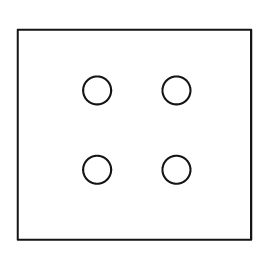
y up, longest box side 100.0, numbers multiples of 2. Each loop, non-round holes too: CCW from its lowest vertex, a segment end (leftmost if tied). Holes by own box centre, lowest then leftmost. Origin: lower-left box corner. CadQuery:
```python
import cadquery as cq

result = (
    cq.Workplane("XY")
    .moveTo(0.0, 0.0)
    .lineTo(100.0, 0.0)
    .lineTo(100.0, 90.0)
    .lineTo(0.0, 90.0)
    .close()
    .moveTo(34.0, 30.0)
    .circle(6.0)
    .moveTo(68.0, 30.0)
    .circle(6.0)
    .moveTo(34.0, 64.0)
    .circle(6.0)
    .moveTo(68.0, 64.0)
    .circle(6.0)
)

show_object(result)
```